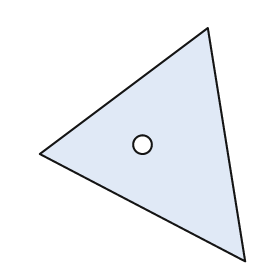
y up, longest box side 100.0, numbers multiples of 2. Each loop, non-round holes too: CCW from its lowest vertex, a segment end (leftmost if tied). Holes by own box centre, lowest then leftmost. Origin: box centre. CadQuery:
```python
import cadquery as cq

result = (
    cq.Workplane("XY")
    .moveTo(44.0, -50.0)
    .lineTo(28.0, 50.0)
    .lineTo(-44.0, -4.0)
    .close()
    .moveTo(0.0, 0.0)
    .circle(4.0)
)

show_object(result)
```